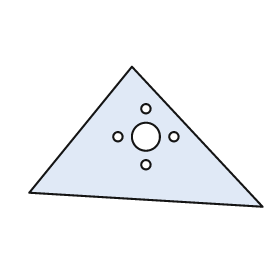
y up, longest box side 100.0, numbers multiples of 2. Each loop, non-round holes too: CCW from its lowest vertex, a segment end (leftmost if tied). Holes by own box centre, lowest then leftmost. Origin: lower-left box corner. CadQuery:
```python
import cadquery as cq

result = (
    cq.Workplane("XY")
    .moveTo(100.0, 0.0)
    .lineTo(44.0, 60.0)
    .lineTo(0.0, 6.0)
    .close()
    .moveTo(50.0, 18.0)
    .circle(2.0)
    .moveTo(38.0, 30.0)
    .circle(2.0)
    .moveTo(50.0, 30.0)
    .circle(6.0)
    .moveTo(62.0, 30.0)
    .circle(2.0)
    .moveTo(50.0, 42.0)
    .circle(2.0)
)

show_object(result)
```